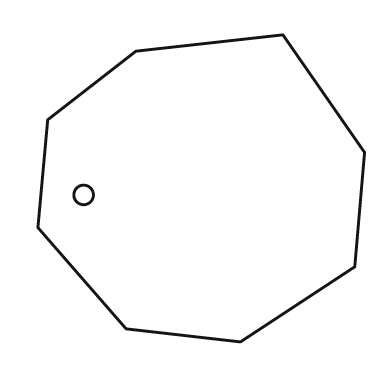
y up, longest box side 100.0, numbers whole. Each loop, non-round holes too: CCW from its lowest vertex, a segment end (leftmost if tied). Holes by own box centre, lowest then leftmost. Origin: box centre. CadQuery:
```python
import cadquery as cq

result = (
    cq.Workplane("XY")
    .moveTo(12.0, -47.0)
    .lineTo(47.0, -24.0)
    .lineTo(50.0, 11.0)
    .lineTo(25.0, 47.0)
    .lineTo(-20.0, 42.0)
    .lineTo(-47.0, 21.0)
    .lineTo(-50.0, -12.0)
    .lineTo(-23.0, -43.0)
    .close()
    .moveTo(-36.0, -2.0)
    .circle(3.0)
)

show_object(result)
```